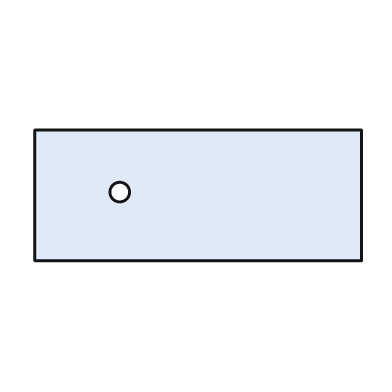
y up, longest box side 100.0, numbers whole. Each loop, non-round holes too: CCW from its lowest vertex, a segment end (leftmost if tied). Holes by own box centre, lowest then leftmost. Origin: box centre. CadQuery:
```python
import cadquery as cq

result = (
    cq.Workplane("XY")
    .moveTo(-50.0, -20.0)
    .lineTo(50.0, -20.0)
    .lineTo(50.0, 20.0)
    .lineTo(-50.0, 20.0)
    .close()
    .moveTo(-24.0, 1.0)
    .circle(3.0)
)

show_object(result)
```